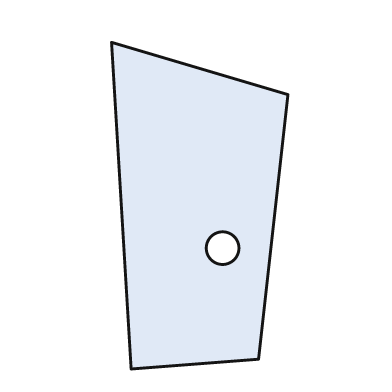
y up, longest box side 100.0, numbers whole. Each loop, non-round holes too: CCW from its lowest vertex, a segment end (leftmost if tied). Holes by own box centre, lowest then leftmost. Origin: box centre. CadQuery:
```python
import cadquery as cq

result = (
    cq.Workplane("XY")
    .moveTo(-21.0, -50.0)
    .lineTo(18.0, -47.0)
    .lineTo(27.0, 34.0)
    .lineTo(-27.0, 50.0)
    .close()
    .moveTo(7.0, -13.0)
    .circle(5.0)
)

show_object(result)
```